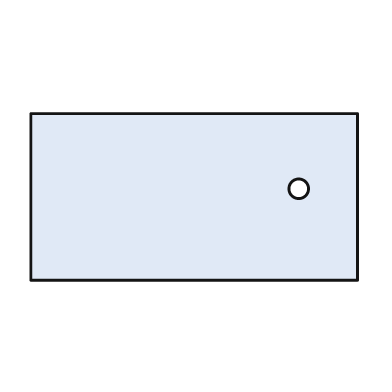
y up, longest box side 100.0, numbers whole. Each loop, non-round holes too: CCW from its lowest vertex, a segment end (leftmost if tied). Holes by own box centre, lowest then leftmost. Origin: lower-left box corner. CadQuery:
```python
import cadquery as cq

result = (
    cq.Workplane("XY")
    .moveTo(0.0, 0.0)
    .lineTo(100.0, 0.0)
    .lineTo(100.0, 51.0)
    .lineTo(0.0, 51.0)
    .close()
    .moveTo(82.0, 28.0)
    .circle(3.0)
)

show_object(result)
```